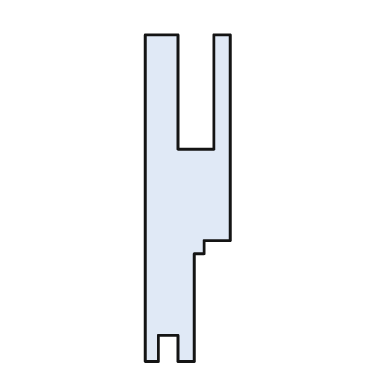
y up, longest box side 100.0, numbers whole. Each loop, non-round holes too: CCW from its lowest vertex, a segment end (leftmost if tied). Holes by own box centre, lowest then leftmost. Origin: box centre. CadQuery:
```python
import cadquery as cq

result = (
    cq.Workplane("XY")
    .moveTo(-13.0, -50.0)
    .lineTo(-9.0, -50.0)
    .lineTo(-9.0, -42.0)
    .lineTo(-3.0, -42.0)
    .lineTo(-3.0, -50.0)
    .lineTo(2.0, -50.0)
    .lineTo(2.0, -17.0)
    .lineTo(5.0, -17.0)
    .lineTo(5.0, -13.0)
    .lineTo(13.0, -13.0)
    .lineTo(13.0, 50.0)
    .lineTo(8.0, 50.0)
    .lineTo(8.0, 15.0)
    .lineTo(-3.0, 15.0)
    .lineTo(-3.0, 50.0)
    .lineTo(-13.0, 50.0)
    .close()
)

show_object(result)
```